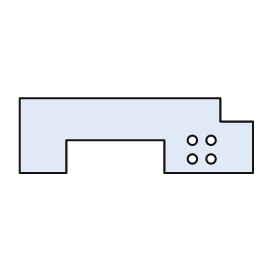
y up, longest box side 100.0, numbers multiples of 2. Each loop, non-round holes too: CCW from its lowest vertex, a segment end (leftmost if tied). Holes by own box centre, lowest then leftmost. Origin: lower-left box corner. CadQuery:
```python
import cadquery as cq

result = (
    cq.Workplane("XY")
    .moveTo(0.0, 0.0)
    .lineTo(20.0, 0.0)
    .lineTo(20.0, 14.0)
    .lineTo(62.0, 14.0)
    .lineTo(62.0, 0.0)
    .lineTo(100.0, 0.0)
    .lineTo(100.0, 22.0)
    .lineTo(86.0, 22.0)
    .lineTo(86.0, 32.0)
    .lineTo(0.0, 32.0)
    .close()
    .moveTo(74.0, 6.0)
    .circle(2.0)
    .moveTo(82.0, 6.0)
    .circle(2.0)
    .moveTo(74.0, 14.0)
    .circle(2.0)
    .moveTo(82.0, 14.0)
    .circle(2.0)
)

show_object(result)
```